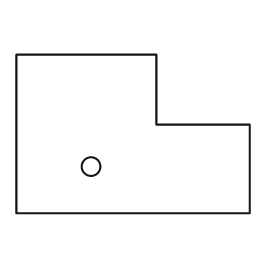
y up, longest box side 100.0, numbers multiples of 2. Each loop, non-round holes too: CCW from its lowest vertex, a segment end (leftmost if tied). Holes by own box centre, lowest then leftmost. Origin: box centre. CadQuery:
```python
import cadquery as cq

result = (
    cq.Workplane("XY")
    .moveTo(-50.0, -34.0)
    .lineTo(50.0, -34.0)
    .lineTo(50.0, 4.0)
    .lineTo(10.0, 4.0)
    .lineTo(10.0, 34.0)
    .lineTo(-50.0, 34.0)
    .close()
    .moveTo(-18.0, -14.0)
    .circle(4.0)
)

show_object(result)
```